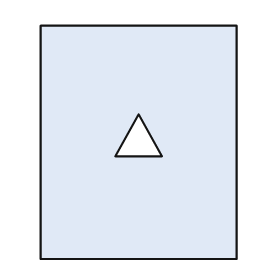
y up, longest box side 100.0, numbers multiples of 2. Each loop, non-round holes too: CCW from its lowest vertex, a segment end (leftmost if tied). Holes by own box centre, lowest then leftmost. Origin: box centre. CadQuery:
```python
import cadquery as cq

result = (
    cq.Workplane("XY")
    .moveTo(-42.0, -50.0)
    .lineTo(42.0, -50.0)
    .lineTo(42.0, 50.0)
    .lineTo(-42.0, 50.0)
    .close()
    .moveTo(-10.0, -6.0)
    .lineTo(10.0, -6.0)
    .lineTo(0.0, 12.0)
    .close()
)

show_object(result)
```